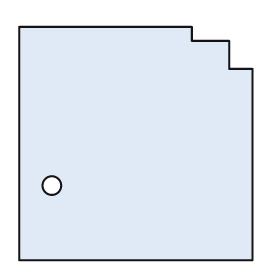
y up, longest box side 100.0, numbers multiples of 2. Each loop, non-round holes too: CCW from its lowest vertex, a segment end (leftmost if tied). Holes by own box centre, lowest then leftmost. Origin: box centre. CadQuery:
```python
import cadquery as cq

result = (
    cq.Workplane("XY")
    .moveTo(-50.0, -50.0)
    .lineTo(50.0, -50.0)
    .lineTo(50.0, 32.0)
    .lineTo(40.0, 32.0)
    .lineTo(40.0, 44.0)
    .lineTo(24.0, 44.0)
    .lineTo(24.0, 50.0)
    .lineTo(-50.0, 50.0)
    .close()
    .moveTo(-36.0, -18.0)
    .circle(4.0)
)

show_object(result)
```